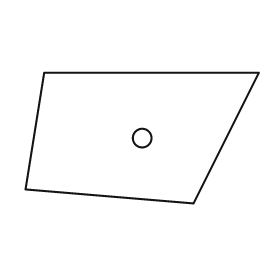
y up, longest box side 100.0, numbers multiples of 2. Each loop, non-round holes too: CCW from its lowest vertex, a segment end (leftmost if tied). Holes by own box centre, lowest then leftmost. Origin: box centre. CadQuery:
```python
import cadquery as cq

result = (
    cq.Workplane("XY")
    .moveTo(22.0, -28.0)
    .lineTo(50.0, 28.0)
    .lineTo(-42.0, 28.0)
    .lineTo(-50.0, -22.0)
    .close()
    .moveTo(0.0, 0.0)
    .circle(4.0)
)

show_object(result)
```